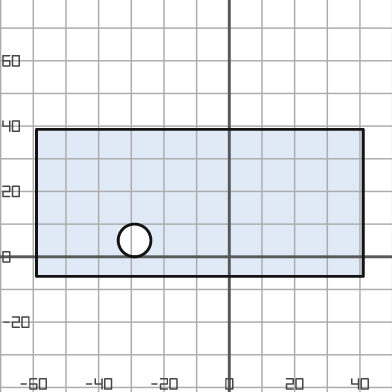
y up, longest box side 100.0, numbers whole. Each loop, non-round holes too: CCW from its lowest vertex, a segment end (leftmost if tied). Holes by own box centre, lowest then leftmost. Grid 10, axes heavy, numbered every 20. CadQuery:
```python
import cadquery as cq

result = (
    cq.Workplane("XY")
    .moveTo(-59.0, -6.0)
    .lineTo(41.0, -6.0)
    .lineTo(41.0, 39.0)
    .lineTo(-59.0, 39.0)
    .close()
    .moveTo(-29.0, 5.0)
    .circle(5.0)
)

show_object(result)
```